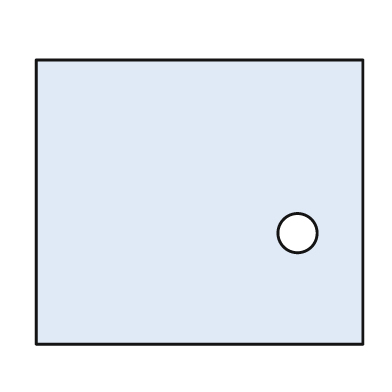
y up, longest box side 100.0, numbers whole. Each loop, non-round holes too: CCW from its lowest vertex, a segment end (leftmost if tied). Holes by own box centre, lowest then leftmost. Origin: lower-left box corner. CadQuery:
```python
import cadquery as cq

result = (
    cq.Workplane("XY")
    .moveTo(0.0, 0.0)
    .lineTo(100.0, 0.0)
    .lineTo(100.0, 87.0)
    .lineTo(0.0, 87.0)
    .close()
    .moveTo(80.0, 34.0)
    .circle(6.0)
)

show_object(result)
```